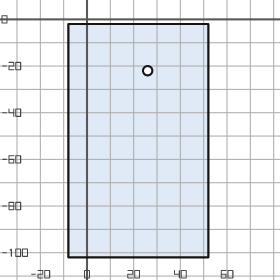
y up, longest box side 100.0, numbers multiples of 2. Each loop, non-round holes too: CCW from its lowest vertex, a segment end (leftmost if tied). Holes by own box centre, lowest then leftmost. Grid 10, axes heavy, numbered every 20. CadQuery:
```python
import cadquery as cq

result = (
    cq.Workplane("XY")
    .moveTo(-8.0, -102.0)
    .lineTo(52.0, -102.0)
    .lineTo(52.0, -2.0)
    .lineTo(-8.0, -2.0)
    .close()
    .moveTo(26.0, -22.0)
    .circle(2.0)
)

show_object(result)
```